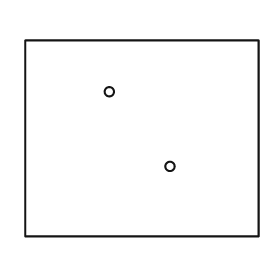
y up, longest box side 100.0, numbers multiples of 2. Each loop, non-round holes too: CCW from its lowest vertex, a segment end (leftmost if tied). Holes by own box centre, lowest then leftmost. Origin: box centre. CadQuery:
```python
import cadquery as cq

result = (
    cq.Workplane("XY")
    .moveTo(-50.0, -42.0)
    .lineTo(50.0, -42.0)
    .lineTo(50.0, 42.0)
    .lineTo(-50.0, 42.0)
    .close()
    .moveTo(12.0, -12.0)
    .circle(2.0)
    .moveTo(-14.0, 20.0)
    .circle(2.0)
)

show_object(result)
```